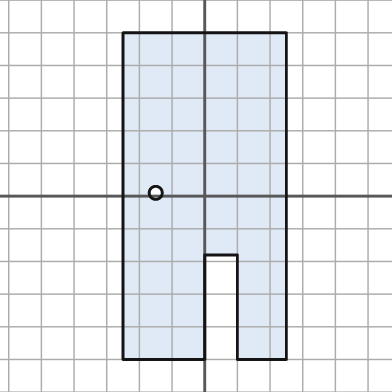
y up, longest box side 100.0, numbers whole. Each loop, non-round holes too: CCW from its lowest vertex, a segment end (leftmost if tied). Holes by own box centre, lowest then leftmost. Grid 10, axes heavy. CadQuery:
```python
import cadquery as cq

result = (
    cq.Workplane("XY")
    .moveTo(-25.0, -50.0)
    .lineTo(0.0, -50.0)
    .lineTo(0.0, -18.0)
    .lineTo(10.0, -18.0)
    .lineTo(10.0, -50.0)
    .lineTo(25.0, -50.0)
    .lineTo(25.0, 50.0)
    .lineTo(-25.0, 50.0)
    .close()
    .moveTo(-15.0, 1.0)
    .circle(2.0)
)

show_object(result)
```